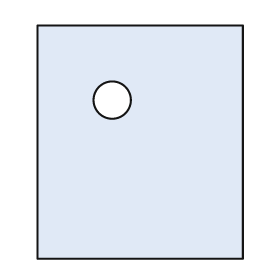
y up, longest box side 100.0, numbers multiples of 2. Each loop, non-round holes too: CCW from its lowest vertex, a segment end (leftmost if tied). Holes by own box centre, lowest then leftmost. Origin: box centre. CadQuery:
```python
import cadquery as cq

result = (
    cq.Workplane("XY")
    .moveTo(-44.0, -50.0)
    .lineTo(44.0, -50.0)
    .lineTo(44.0, 50.0)
    .lineTo(-44.0, 50.0)
    .close()
    .moveTo(-12.0, 18.0)
    .circle(8.0)
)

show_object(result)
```